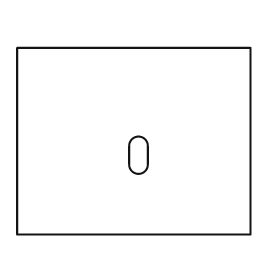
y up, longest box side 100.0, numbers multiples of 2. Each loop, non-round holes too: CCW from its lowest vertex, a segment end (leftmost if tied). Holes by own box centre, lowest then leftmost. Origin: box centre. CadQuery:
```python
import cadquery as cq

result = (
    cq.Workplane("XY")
    .moveTo(-50.0, -40.0)
    .lineTo(50.0, -40.0)
    .lineTo(50.0, 40.0)
    .lineTo(-50.0, 40.0)
    .close()
    .moveTo(-2.0, -10.0)
    .threePointArc((2.0, -14.0), (6.0, -10.0))
    .lineTo(6.0, -2.0)
    .threePointArc((2.0, 2.0), (-2.0, -2.0))
    .close()
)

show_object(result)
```